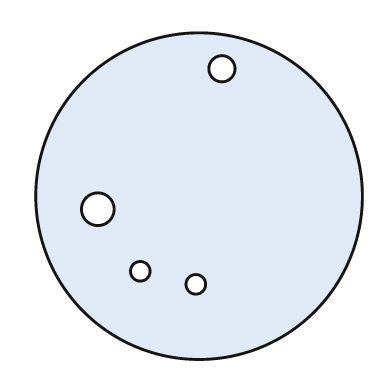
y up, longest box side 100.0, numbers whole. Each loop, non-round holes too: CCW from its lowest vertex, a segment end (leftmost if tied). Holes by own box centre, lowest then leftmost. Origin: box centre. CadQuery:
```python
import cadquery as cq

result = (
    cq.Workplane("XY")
    .moveTo(0.0, 0.0)
    .circle(50.0)
    .moveTo(-1.0, -27.0)
    .circle(3.0)
    .moveTo(-18.0, -23.0)
    .circle(3.0)
    .moveTo(-31.0, -4.0)
    .circle(5.0)
    .moveTo(7.0, 39.0)
    .circle(4.0)
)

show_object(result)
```